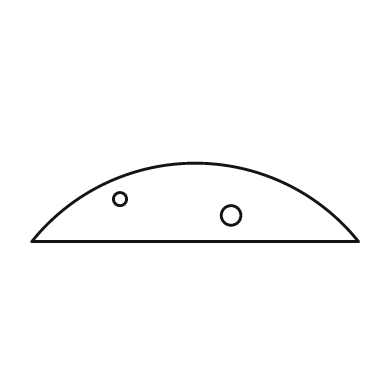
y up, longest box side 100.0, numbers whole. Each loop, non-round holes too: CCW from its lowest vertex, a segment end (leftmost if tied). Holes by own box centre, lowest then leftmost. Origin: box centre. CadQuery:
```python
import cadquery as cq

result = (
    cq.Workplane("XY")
    .moveTo(-50.0, -12.0)
    .lineTo(50.0, -12.0)
    .threePointArc((0.0, 12.0), (-50.0, -12.0))
    .close()
    .moveTo(11.0, -4.0)
    .circle(3.0)
    .moveTo(-23.0, 1.0)
    .circle(2.0)
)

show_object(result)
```